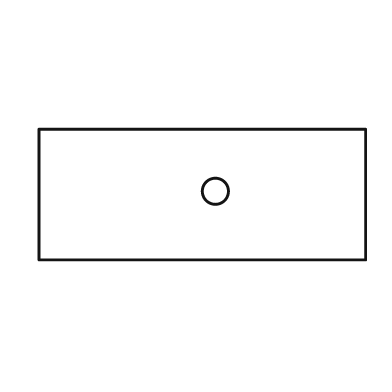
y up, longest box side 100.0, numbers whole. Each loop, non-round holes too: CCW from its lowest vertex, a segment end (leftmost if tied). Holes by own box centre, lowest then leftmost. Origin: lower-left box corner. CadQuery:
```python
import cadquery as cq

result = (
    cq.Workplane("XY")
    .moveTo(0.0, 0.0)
    .lineTo(100.0, 0.0)
    .lineTo(100.0, 40.0)
    .lineTo(0.0, 40.0)
    .close()
    .moveTo(54.0, 21.0)
    .circle(4.0)
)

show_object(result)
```